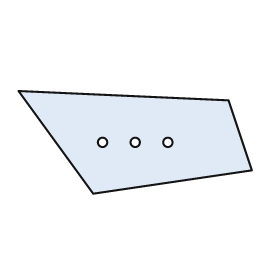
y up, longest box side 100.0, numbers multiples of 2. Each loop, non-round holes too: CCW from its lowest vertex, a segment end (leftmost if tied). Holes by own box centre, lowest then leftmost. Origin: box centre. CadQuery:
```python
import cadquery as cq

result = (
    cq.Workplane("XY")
    .moveTo(-18.0, -22.0)
    .lineTo(50.0, -12.0)
    .lineTo(40.0, 18.0)
    .lineTo(-50.0, 22.0)
    .close()
    .moveTo(-14.0, 0.0)
    .circle(2.0)
    .moveTo(0.0, 0.0)
    .circle(2.0)
    .moveTo(14.0, 0.0)
    .circle(2.0)
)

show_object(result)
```